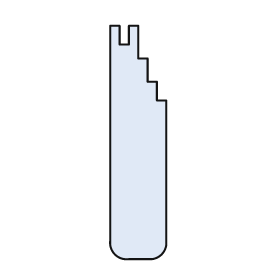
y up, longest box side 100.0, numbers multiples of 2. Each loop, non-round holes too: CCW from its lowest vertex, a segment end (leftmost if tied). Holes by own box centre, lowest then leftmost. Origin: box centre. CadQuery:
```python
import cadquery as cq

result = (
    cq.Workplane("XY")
    .moveTo(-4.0, -50.0)
    .lineTo(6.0, -50.0)
    .threePointArc((10.0, -48.0), (12.0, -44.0))
    .lineTo(12.0, 18.0)
    .lineTo(8.0, 18.0)
    .lineTo(8.0, 26.0)
    .lineTo(4.0, 26.0)
    .lineTo(4.0, 36.0)
    .lineTo(0.0, 36.0)
    .lineTo(0.0, 50.0)
    .lineTo(-4.0, 50.0)
    .lineTo(-4.0, 42.0)
    .lineTo(-8.0, 42.0)
    .lineTo(-8.0, 50.0)
    .lineTo(-12.0, 50.0)
    .lineTo(-12.0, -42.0)
    .threePointArc((-10.0, -48.0), (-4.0, -50.0))
    .close()
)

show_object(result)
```